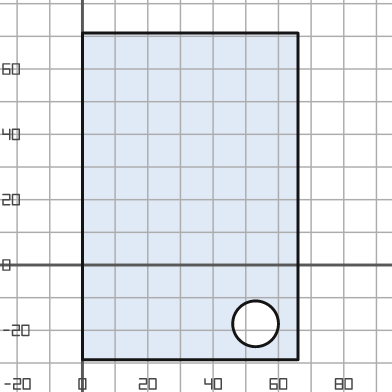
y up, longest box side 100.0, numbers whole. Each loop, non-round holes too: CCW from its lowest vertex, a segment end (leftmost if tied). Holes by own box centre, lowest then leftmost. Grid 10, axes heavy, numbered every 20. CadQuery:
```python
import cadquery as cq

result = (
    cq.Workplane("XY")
    .moveTo(0.0, -29.0)
    .lineTo(66.0, -29.0)
    .lineTo(66.0, 71.0)
    .lineTo(0.0, 71.0)
    .close()
    .moveTo(53.0, -18.0)
    .circle(7.0)
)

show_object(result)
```